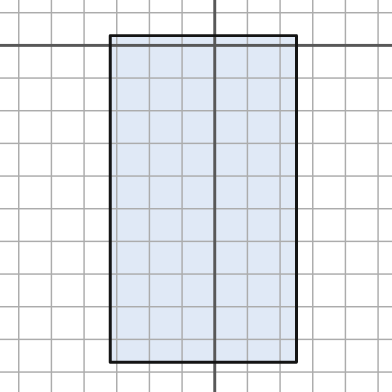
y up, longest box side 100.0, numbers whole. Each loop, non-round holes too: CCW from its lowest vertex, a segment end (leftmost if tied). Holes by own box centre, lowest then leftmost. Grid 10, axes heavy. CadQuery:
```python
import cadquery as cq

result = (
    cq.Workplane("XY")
    .moveTo(-32.0, -97.0)
    .lineTo(25.0, -97.0)
    .lineTo(25.0, 3.0)
    .lineTo(-32.0, 3.0)
    .close()
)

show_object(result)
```